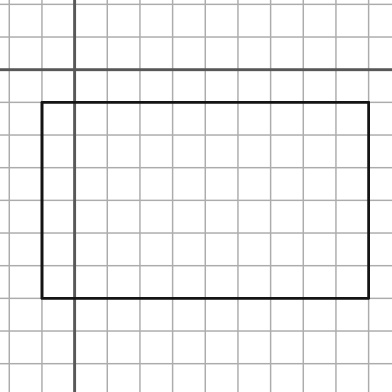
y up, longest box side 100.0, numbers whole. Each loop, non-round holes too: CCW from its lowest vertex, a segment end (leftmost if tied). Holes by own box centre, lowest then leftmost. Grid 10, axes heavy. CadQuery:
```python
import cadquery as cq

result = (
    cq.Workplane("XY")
    .moveTo(-10.0, -70.0)
    .lineTo(90.0, -70.0)
    .lineTo(90.0, -10.0)
    .lineTo(-10.0, -10.0)
    .close()
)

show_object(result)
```